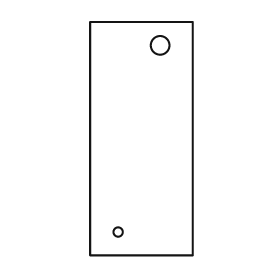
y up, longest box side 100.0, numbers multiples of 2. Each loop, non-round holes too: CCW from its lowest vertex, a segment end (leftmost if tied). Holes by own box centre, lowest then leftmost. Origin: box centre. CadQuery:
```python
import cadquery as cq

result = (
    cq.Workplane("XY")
    .moveTo(-22.0, -50.0)
    .lineTo(22.0, -50.0)
    .lineTo(22.0, 50.0)
    .lineTo(-22.0, 50.0)
    .close()
    .moveTo(-10.0, -40.0)
    .circle(2.0)
    .moveTo(8.0, 40.0)
    .circle(4.0)
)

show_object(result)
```